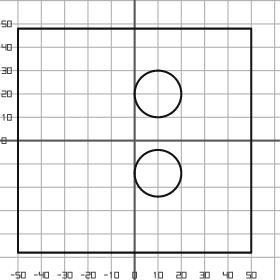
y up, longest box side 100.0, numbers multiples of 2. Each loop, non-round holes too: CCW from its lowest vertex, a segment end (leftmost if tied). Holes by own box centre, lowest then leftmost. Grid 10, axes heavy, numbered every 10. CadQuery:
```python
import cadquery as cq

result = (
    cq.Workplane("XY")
    .moveTo(-50.0, -48.0)
    .lineTo(50.0, -48.0)
    .lineTo(50.0, 48.0)
    .lineTo(-50.0, 48.0)
    .close()
    .moveTo(10.0, -14.0)
    .circle(10.0)
    .moveTo(10.0, 20.0)
    .circle(10.0)
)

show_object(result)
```